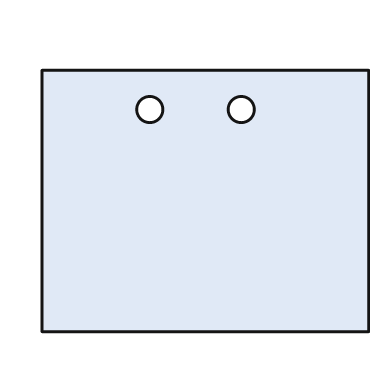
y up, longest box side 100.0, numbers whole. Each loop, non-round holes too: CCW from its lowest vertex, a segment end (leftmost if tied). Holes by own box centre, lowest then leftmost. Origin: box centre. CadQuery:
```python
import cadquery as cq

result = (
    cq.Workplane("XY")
    .moveTo(-50.0, -40.0)
    .lineTo(50.0, -40.0)
    .lineTo(50.0, 40.0)
    .lineTo(-50.0, 40.0)
    .close()
    .moveTo(-17.0, 28.0)
    .circle(4.0)
    .moveTo(11.0, 28.0)
    .circle(4.0)
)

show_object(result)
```